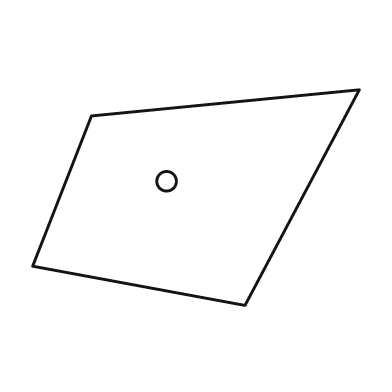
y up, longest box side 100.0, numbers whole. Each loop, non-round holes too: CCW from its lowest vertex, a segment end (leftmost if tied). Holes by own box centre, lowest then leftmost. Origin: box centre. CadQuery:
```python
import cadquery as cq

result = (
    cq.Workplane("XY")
    .moveTo(15.0, -33.0)
    .lineTo(50.0, 33.0)
    .lineTo(-32.0, 25.0)
    .lineTo(-50.0, -21.0)
    .close()
    .moveTo(-9.0, 5.0)
    .circle(3.0)
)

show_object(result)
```